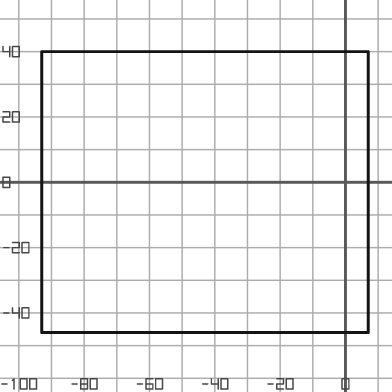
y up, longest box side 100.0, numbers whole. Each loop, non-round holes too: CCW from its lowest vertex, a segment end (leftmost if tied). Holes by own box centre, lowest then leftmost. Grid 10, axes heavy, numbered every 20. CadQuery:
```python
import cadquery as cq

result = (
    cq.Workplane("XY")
    .moveTo(-93.0, -46.0)
    .lineTo(7.0, -46.0)
    .lineTo(7.0, 40.0)
    .lineTo(-93.0, 40.0)
    .close()
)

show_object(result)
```